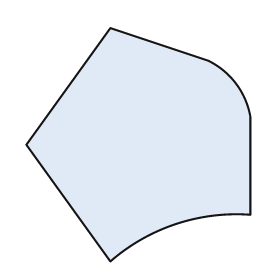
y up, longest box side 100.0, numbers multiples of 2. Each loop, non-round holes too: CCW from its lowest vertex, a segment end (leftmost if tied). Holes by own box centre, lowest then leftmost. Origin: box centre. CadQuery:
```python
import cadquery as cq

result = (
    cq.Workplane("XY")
    .moveTo(-12.0, -50.0)
    .threePointArc((16.0, -34.0), (48.0, -30.0))
    .lineTo(48.0, 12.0)
    .threePointArc((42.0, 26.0), (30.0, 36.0))
    .lineTo(-12.0, 50.0)
    .lineTo(-48.0, 0.0)
    .close()
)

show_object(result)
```